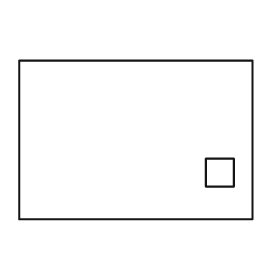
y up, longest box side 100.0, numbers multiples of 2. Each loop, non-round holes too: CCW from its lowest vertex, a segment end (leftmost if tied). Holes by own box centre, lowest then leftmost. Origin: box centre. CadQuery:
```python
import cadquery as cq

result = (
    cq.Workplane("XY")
    .moveTo(-50.0, -34.0)
    .lineTo(50.0, -34.0)
    .lineTo(50.0, 34.0)
    .lineTo(-50.0, 34.0)
    .close()
    .moveTo(30.0, -20.0)
    .lineTo(42.0, -20.0)
    .lineTo(42.0, -8.0)
    .lineTo(30.0, -8.0)
    .close()
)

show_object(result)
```